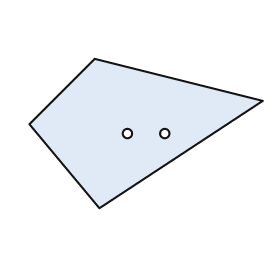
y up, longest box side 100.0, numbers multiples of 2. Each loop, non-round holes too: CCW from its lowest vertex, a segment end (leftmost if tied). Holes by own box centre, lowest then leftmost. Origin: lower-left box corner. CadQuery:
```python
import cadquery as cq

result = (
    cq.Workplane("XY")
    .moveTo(30.0, 0.0)
    .lineTo(100.0, 46.0)
    .lineTo(28.0, 64.0)
    .lineTo(0.0, 36.0)
    .close()
    .moveTo(42.0, 32.0)
    .circle(2.0)
    .moveTo(58.0, 32.0)
    .circle(2.0)
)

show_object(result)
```